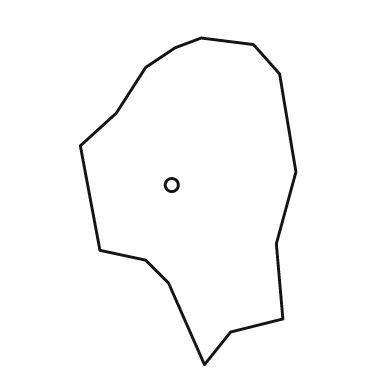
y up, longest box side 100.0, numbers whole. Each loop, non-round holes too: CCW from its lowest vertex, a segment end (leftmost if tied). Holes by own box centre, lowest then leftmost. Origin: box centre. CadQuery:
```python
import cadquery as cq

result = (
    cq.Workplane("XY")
    .moveTo(5.0, -50.0)
    .lineTo(13.0, -40.0)
    .lineTo(29.0, -36.0)
    .lineTo(27.0, -13.0)
    .lineTo(33.0, 9.0)
    .lineTo(28.0, 39.0)
    .lineTo(20.0, 48.0)
    .lineTo(4.0, 50.0)
    .lineTo(-4.0, 47.0)
    .lineTo(-13.0, 41.0)
    .lineTo(-22.0, 27.0)
    .lineTo(-33.0, 17.0)
    .lineTo(-27.0, -15.0)
    .lineTo(-13.0, -18.0)
    .lineTo(-6.0, -25.0)
    .close()
    .moveTo(-5.0, 5.0)
    .circle(2.0)
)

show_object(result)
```